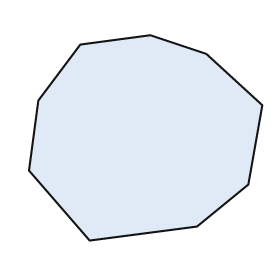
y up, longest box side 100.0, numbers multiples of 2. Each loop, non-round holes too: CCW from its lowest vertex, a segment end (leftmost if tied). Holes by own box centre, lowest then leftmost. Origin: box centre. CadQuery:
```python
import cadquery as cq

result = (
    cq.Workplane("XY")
    .moveTo(-24.0, -44.0)
    .lineTo(22.0, -38.0)
    .lineTo(44.0, -20.0)
    .lineTo(50.0, 14.0)
    .lineTo(26.0, 36.0)
    .lineTo(2.0, 44.0)
    .lineTo(-28.0, 40.0)
    .lineTo(-46.0, 16.0)
    .lineTo(-50.0, -14.0)
    .close()
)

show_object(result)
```